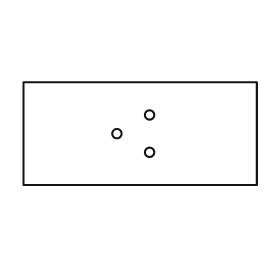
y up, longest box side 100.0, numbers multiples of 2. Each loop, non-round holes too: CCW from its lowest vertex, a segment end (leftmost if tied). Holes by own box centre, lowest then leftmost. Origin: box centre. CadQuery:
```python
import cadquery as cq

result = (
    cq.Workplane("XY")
    .moveTo(-50.0, -22.0)
    .lineTo(50.0, -22.0)
    .lineTo(50.0, 22.0)
    .lineTo(-50.0, 22.0)
    .close()
    .moveTo(4.0, -8.0)
    .circle(2.0)
    .moveTo(-10.0, 0.0)
    .circle(2.0)
    .moveTo(4.0, 8.0)
    .circle(2.0)
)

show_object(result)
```